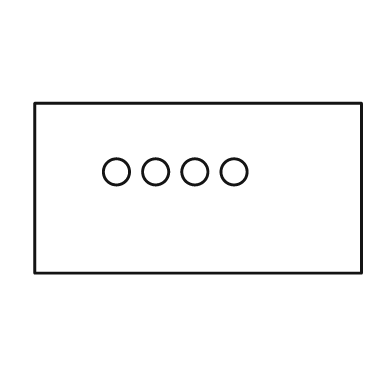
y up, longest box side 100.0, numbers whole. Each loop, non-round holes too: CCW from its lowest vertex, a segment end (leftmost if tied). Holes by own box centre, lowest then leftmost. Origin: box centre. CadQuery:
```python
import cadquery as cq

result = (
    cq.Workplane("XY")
    .moveTo(-50.0, -26.0)
    .lineTo(50.0, -26.0)
    .lineTo(50.0, 26.0)
    .lineTo(-50.0, 26.0)
    .close()
    .moveTo(-25.0, 5.0)
    .circle(4.0)
    .moveTo(-13.0, 5.0)
    .circle(4.0)
    .moveTo(-1.0, 5.0)
    .circle(4.0)
    .moveTo(11.0, 5.0)
    .circle(4.0)
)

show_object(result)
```